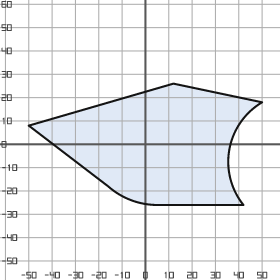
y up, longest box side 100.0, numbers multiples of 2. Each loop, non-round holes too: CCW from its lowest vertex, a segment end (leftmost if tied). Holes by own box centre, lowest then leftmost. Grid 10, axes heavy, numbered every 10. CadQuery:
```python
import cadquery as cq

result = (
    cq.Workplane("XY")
    .moveTo(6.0, -26.0)
    .lineTo(42.0, -26.0)
    .threePointArc((36.0, -2.0), (50.0, 18.0))
    .lineTo(12.0, 26.0)
    .lineTo(-50.0, 8.0)
    .lineTo(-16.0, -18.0)
    .threePointArc((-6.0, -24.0), (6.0, -26.0))
    .close()
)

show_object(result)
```